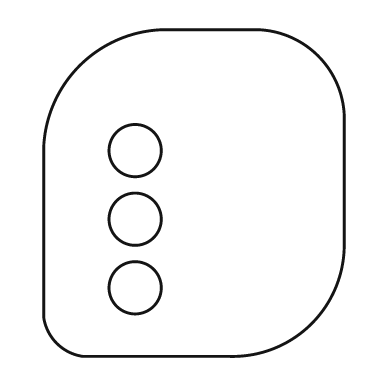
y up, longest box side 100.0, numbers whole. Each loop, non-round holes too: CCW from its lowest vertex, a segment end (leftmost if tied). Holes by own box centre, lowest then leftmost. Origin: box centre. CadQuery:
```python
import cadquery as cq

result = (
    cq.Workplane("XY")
    .moveTo(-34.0, -50.0)
    .lineTo(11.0, -50.0)
    .threePointArc((36.0, -40.0), (46.0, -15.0))
    .lineTo(46.0, 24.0)
    .threePointArc((38.0, 42.0), (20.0, 50.0))
    .lineTo(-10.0, 50.0)
    .threePointArc((-35.0, 39.0), (-46.0, 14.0))
    .lineTo(-46.0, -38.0)
    .threePointArc((-42.0, -46.0), (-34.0, -50.0))
    .close()
    .moveTo(-18.0, -29.0)
    .circle(8.0)
    .moveTo(-18.0, -8.0)
    .circle(8.0)
    .moveTo(-18.0, 13.0)
    .circle(8.0)
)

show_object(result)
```